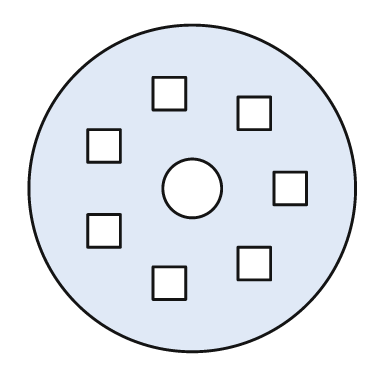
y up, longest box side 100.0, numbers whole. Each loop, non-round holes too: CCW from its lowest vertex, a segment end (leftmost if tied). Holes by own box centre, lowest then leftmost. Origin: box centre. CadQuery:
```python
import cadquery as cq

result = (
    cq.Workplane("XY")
    .moveTo(0.0, 0.0)
    .circle(50.0)
    .moveTo(-12.0, -34.0)
    .lineTo(-2.0, -34.0)
    .lineTo(-2.0, -24.0)
    .lineTo(-12.0, -24.0)
    .close()
    .moveTo(14.0, -28.0)
    .lineTo(24.0, -28.0)
    .lineTo(24.0, -18.0)
    .lineTo(14.0, -18.0)
    .close()
    .moveTo(-32.0, -18.0)
    .lineTo(-22.0, -18.0)
    .lineTo(-22.0, -8.0)
    .lineTo(-32.0, -8.0)
    .close()
    .moveTo(0.0, 0.0)
    .circle(9.0)
    .moveTo(25.0, -5.0)
    .lineTo(35.0, -5.0)
    .lineTo(35.0, 5.0)
    .lineTo(25.0, 5.0)
    .close()
    .moveTo(-32.0, 8.0)
    .lineTo(-22.0, 8.0)
    .lineTo(-22.0, 18.0)
    .lineTo(-32.0, 18.0)
    .close()
    .moveTo(14.0, 18.0)
    .lineTo(24.0, 18.0)
    .lineTo(24.0, 28.0)
    .lineTo(14.0, 28.0)
    .close()
    .moveTo(-12.0, 24.0)
    .lineTo(-2.0, 24.0)
    .lineTo(-2.0, 34.0)
    .lineTo(-12.0, 34.0)
    .close()
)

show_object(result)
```